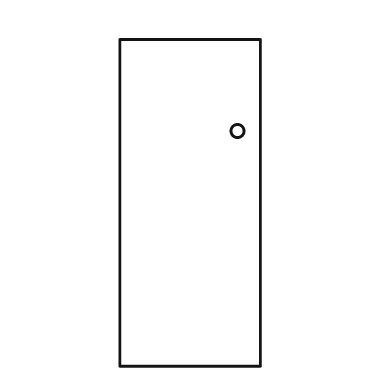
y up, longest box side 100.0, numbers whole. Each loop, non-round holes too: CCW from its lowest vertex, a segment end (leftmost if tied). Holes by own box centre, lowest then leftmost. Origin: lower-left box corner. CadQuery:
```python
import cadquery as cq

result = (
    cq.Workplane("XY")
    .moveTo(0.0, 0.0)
    .lineTo(43.0, 0.0)
    .lineTo(43.0, 100.0)
    .lineTo(0.0, 100.0)
    .close()
    .moveTo(36.0, 72.0)
    .circle(2.0)
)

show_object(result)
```